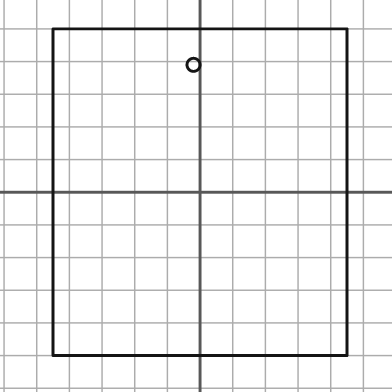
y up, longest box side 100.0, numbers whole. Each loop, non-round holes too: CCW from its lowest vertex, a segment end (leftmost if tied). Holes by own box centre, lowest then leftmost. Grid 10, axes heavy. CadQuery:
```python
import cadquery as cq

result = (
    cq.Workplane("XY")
    .moveTo(-45.0, -50.0)
    .lineTo(45.0, -50.0)
    .lineTo(45.0, 50.0)
    .lineTo(-45.0, 50.0)
    .close()
    .moveTo(-2.0, 39.0)
    .circle(2.0)
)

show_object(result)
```